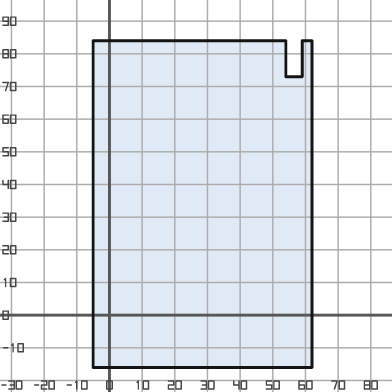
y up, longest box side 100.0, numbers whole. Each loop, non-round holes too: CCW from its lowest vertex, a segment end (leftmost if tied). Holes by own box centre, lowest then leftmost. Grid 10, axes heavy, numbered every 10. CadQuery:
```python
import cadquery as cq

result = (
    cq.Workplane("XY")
    .moveTo(-5.0, -16.0)
    .lineTo(62.0, -16.0)
    .lineTo(62.0, 84.0)
    .lineTo(59.0, 84.0)
    .lineTo(59.0, 73.0)
    .lineTo(54.0, 73.0)
    .lineTo(54.0, 84.0)
    .lineTo(-5.0, 84.0)
    .close()
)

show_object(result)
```